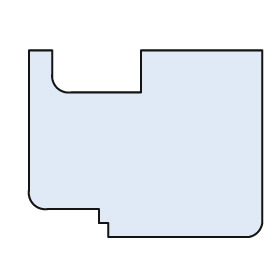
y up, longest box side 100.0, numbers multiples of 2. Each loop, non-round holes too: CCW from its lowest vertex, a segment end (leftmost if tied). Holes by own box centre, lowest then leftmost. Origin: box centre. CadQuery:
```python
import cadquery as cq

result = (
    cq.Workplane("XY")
    .moveTo(-16.0, -40.0)
    .lineTo(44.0, -40.0)
    .threePointArc((48.0, -38.0), (50.0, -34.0))
    .lineTo(50.0, 40.0)
    .lineTo(-2.0, 40.0)
    .lineTo(-2.0, 22.0)
    .lineTo(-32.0, 22.0)
    .threePointArc((-38.0, 24.0), (-40.0, 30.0))
    .lineTo(-40.0, 40.0)
    .lineTo(-50.0, 40.0)
    .lineTo(-50.0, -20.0)
    .threePointArc((-48.0, -26.0), (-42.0, -28.0))
    .lineTo(-20.0, -28.0)
    .lineTo(-20.0, -34.0)
    .lineTo(-16.0, -34.0)
    .close()
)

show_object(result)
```